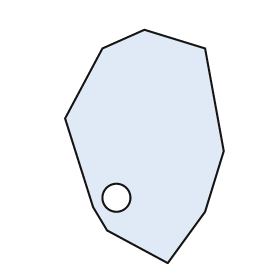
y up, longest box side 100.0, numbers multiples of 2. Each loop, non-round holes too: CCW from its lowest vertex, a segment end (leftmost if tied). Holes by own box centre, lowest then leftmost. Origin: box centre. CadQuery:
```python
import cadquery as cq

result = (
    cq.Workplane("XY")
    .moveTo(10.0, -50.0)
    .lineTo(26.0, -28.0)
    .lineTo(34.0, -2.0)
    .lineTo(26.0, 42.0)
    .lineTo(0.0, 50.0)
    .lineTo(-18.0, 42.0)
    .lineTo(-34.0, 12.0)
    .lineTo(-22.0, -26.0)
    .lineTo(-16.0, -36.0)
    .close()
    .moveTo(-12.0, -22.0)
    .circle(6.0)
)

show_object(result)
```